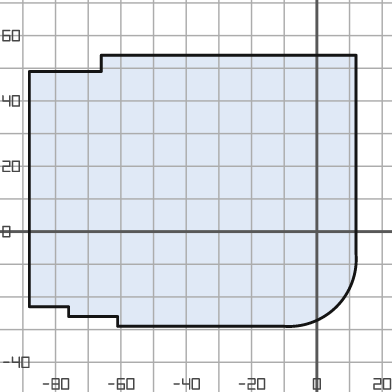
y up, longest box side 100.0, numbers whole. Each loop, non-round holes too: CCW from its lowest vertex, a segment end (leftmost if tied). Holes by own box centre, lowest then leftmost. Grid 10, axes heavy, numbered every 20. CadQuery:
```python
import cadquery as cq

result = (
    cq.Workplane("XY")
    .moveTo(-61.0, -29.0)
    .lineTo(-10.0, -29.0)
    .threePointArc((6.0, -23.0), (12.0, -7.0))
    .lineTo(12.0, 54.0)
    .lineTo(-66.0, 54.0)
    .lineTo(-66.0, 49.0)
    .lineTo(-88.0, 49.0)
    .lineTo(-88.0, -23.0)
    .lineTo(-76.0, -23.0)
    .lineTo(-76.0, -26.0)
    .lineTo(-61.0, -26.0)
    .close()
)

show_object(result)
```